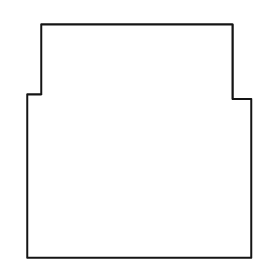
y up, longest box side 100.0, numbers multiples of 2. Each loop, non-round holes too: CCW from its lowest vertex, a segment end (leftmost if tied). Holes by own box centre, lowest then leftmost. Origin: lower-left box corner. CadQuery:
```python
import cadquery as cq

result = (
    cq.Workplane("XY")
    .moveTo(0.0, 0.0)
    .lineTo(96.0, 0.0)
    .lineTo(96.0, 68.0)
    .lineTo(88.0, 68.0)
    .lineTo(88.0, 100.0)
    .lineTo(6.0, 100.0)
    .lineTo(6.0, 70.0)
    .lineTo(0.0, 70.0)
    .close()
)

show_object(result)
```